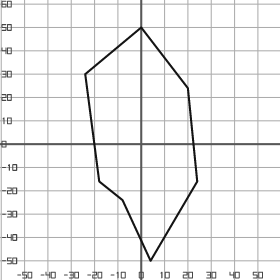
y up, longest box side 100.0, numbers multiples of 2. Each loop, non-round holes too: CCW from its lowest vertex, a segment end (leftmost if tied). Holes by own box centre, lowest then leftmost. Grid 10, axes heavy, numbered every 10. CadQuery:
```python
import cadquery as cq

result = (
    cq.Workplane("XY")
    .moveTo(4.0, -50.0)
    .lineTo(24.0, -16.0)
    .lineTo(20.0, 24.0)
    .lineTo(0.0, 50.0)
    .lineTo(-24.0, 30.0)
    .lineTo(-18.0, -16.0)
    .lineTo(-8.0, -24.0)
    .close()
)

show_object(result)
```